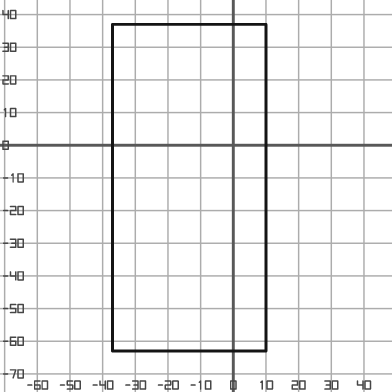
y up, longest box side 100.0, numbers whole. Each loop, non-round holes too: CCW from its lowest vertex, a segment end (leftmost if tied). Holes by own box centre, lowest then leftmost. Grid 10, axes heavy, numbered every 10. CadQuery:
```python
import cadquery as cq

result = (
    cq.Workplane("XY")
    .moveTo(-37.0, -63.0)
    .lineTo(10.0, -63.0)
    .lineTo(10.0, 37.0)
    .lineTo(-37.0, 37.0)
    .close()
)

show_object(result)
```